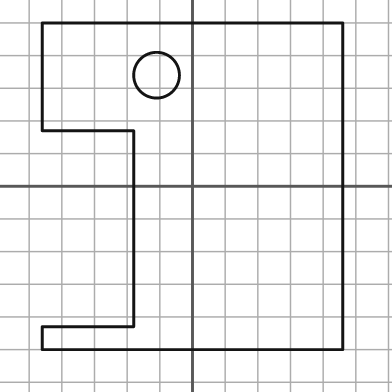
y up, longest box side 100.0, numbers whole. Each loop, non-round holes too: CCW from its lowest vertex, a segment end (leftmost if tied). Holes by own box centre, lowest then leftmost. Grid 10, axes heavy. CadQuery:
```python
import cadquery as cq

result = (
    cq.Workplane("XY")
    .moveTo(-46.0, -50.0)
    .lineTo(46.0, -50.0)
    .lineTo(46.0, 50.0)
    .lineTo(-46.0, 50.0)
    .lineTo(-46.0, 17.0)
    .lineTo(-18.0, 17.0)
    .lineTo(-18.0, -43.0)
    .lineTo(-46.0, -43.0)
    .close()
    .moveTo(-11.0, 34.0)
    .circle(7.0)
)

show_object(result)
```